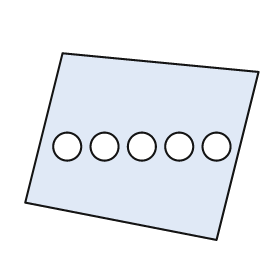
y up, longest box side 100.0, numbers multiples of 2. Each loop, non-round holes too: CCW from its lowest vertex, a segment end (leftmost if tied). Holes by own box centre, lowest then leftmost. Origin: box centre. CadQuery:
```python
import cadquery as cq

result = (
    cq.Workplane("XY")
    .moveTo(32.0, -40.0)
    .lineTo(50.0, 32.0)
    .lineTo(-34.0, 40.0)
    .lineTo(-50.0, -24.0)
    .close()
    .moveTo(-32.0, 0.0)
    .circle(6.0)
    .moveTo(-16.0, 0.0)
    .circle(6.0)
    .moveTo(0.0, 0.0)
    .circle(6.0)
    .moveTo(16.0, 0.0)
    .circle(6.0)
    .moveTo(32.0, 0.0)
    .circle(6.0)
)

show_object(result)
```